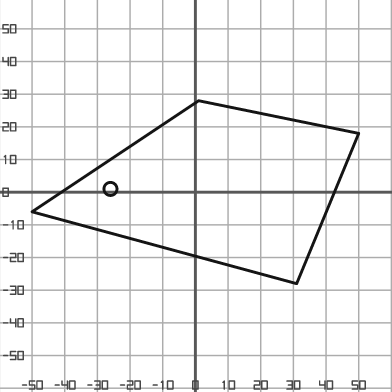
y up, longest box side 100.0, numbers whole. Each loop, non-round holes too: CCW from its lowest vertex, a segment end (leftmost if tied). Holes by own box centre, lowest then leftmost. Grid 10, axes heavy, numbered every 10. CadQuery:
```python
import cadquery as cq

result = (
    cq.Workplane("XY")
    .moveTo(31.0, -28.0)
    .lineTo(50.0, 18.0)
    .lineTo(1.0, 28.0)
    .lineTo(-50.0, -6.0)
    .close()
    .moveTo(-26.0, 1.0)
    .circle(2.0)
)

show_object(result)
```